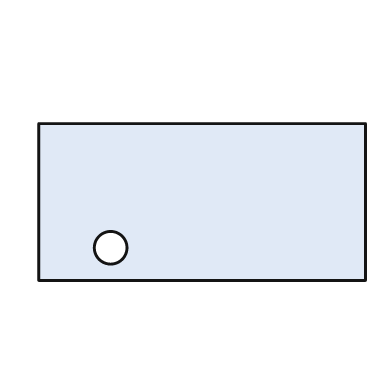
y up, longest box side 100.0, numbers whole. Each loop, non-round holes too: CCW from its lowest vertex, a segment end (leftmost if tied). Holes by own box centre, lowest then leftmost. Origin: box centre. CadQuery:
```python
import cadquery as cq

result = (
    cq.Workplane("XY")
    .moveTo(-50.0, -24.0)
    .lineTo(50.0, -24.0)
    .lineTo(50.0, 24.0)
    .lineTo(-50.0, 24.0)
    .close()
    .moveTo(-28.0, -14.0)
    .circle(5.0)
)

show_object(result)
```